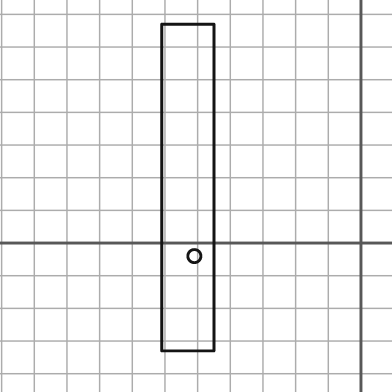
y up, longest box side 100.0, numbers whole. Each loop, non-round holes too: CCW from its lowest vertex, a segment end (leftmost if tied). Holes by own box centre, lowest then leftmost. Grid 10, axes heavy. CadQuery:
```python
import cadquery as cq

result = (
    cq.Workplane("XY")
    .moveTo(-61.0, -33.0)
    .lineTo(-45.0, -33.0)
    .lineTo(-45.0, 67.0)
    .lineTo(-61.0, 67.0)
    .close()
    .moveTo(-51.0, -4.0)
    .circle(2.0)
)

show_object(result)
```